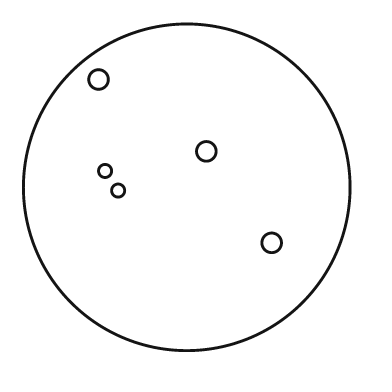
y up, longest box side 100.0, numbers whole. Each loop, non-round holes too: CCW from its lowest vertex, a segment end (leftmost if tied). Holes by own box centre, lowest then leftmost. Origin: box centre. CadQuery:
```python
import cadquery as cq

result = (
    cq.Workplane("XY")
    .moveTo(0.0, 0.0)
    .circle(50.0)
    .moveTo(26.0, -17.0)
    .circle(3.0)
    .moveTo(-21.0, -1.0)
    .circle(2.0)
    .moveTo(-25.0, 5.0)
    .circle(2.0)
    .moveTo(6.0, 11.0)
    .circle(3.0)
    .moveTo(-27.0, 33.0)
    .circle(3.0)
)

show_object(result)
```